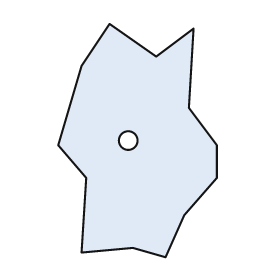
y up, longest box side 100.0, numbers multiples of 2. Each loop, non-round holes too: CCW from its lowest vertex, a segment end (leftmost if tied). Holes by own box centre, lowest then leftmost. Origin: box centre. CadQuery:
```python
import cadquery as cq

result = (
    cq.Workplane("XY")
    .moveTo(12.0, -50.0)
    .lineTo(20.0, -32.0)
    .lineTo(34.0, -16.0)
    .lineTo(34.0, -2.0)
    .lineTo(22.0, 14.0)
    .lineTo(24.0, 48.0)
    .lineTo(8.0, 36.0)
    .lineTo(-12.0, 50.0)
    .lineTo(-24.0, 32.0)
    .lineTo(-34.0, -2.0)
    .lineTo(-22.0, -16.0)
    .lineTo(-24.0, -48.0)
    .lineTo(-2.0, -46.0)
    .close()
    .moveTo(-4.0, 0.0)
    .circle(4.0)
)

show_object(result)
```